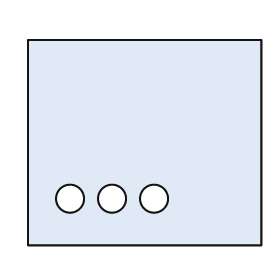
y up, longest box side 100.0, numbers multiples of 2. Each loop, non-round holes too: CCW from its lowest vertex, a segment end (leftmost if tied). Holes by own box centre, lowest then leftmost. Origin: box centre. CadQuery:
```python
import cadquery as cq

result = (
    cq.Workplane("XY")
    .moveTo(-50.0, -44.0)
    .lineTo(50.0, -44.0)
    .lineTo(50.0, 44.0)
    .lineTo(-50.0, 44.0)
    .close()
    .moveTo(-32.0, -24.0)
    .circle(6.0)
    .moveTo(-14.0, -24.0)
    .circle(6.0)
    .moveTo(4.0, -24.0)
    .circle(6.0)
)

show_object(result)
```